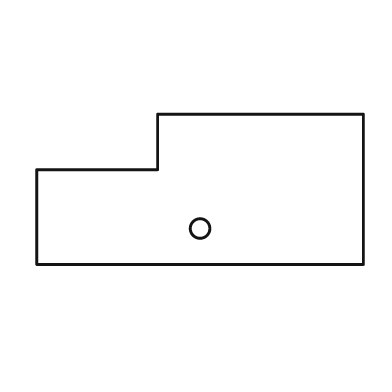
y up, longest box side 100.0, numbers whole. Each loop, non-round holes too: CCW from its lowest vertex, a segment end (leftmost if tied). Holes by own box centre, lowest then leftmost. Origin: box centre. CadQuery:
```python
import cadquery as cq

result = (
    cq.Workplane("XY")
    .moveTo(-50.0, -23.0)
    .lineTo(50.0, -23.0)
    .lineTo(50.0, 23.0)
    .lineTo(-13.0, 23.0)
    .lineTo(-13.0, 6.0)
    .lineTo(-50.0, 6.0)
    .close()
    .moveTo(0.0, -12.0)
    .circle(3.0)
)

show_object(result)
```